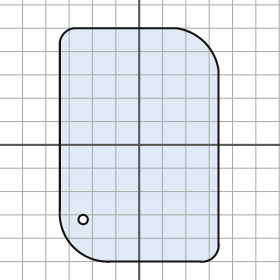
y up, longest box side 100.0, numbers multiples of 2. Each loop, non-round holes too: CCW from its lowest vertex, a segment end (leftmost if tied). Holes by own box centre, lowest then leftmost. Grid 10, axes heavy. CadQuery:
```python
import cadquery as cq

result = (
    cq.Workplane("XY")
    .moveTo(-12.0, -50.0)
    .lineTo(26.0, -50.0)
    .threePointArc((32.0, -48.0), (34.0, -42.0))
    .lineTo(34.0, 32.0)
    .threePointArc((28.0, 44.0), (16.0, 50.0))
    .lineTo(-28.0, 50.0)
    .threePointArc((-32.0, 48.0), (-34.0, 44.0))
    .lineTo(-34.0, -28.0)
    .threePointArc((-28.0, -44.0), (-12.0, -50.0))
    .close()
    .moveTo(-24.0, -32.0)
    .circle(2.0)
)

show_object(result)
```